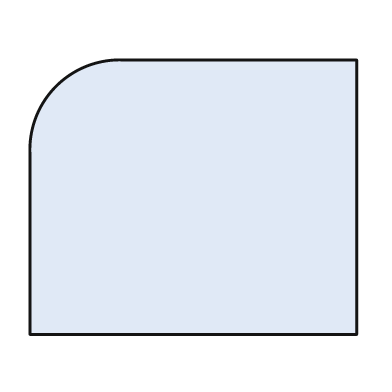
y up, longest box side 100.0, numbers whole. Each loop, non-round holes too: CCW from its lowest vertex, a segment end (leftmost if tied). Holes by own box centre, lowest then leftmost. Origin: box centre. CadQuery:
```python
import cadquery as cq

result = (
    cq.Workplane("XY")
    .moveTo(-50.0, -42.0)
    .lineTo(50.0, -42.0)
    .lineTo(50.0, 42.0)
    .lineTo(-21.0, 42.0)
    .threePointArc((-42.0, 34.0), (-50.0, 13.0))
    .close()
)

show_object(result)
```